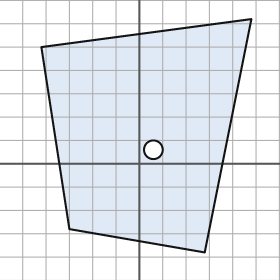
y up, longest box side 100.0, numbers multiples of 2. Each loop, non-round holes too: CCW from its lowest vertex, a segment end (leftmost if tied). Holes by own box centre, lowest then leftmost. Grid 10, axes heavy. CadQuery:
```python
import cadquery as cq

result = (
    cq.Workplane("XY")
    .moveTo(28.0, -38.0)
    .lineTo(48.0, 62.0)
    .lineTo(-42.0, 50.0)
    .lineTo(-30.0, -28.0)
    .close()
    .moveTo(6.0, 6.0)
    .circle(4.0)
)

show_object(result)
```